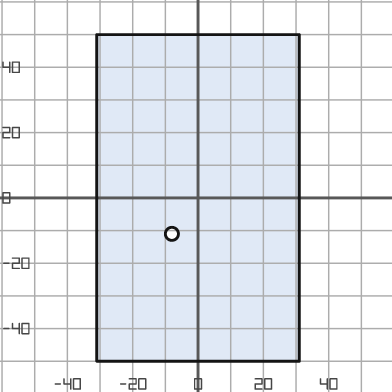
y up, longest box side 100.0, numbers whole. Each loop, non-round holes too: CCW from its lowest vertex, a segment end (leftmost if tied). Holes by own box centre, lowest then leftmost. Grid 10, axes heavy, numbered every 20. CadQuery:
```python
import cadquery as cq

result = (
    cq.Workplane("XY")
    .moveTo(-31.0, -50.0)
    .lineTo(31.0, -50.0)
    .lineTo(31.0, 50.0)
    .lineTo(-31.0, 50.0)
    .close()
    .moveTo(-8.0, -11.0)
    .circle(2.0)
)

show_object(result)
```